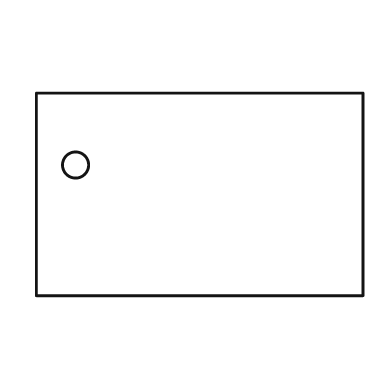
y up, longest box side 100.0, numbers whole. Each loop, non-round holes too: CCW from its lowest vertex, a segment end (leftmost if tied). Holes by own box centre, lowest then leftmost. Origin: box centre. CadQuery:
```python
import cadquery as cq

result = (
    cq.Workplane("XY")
    .moveTo(-50.0, -31.0)
    .lineTo(50.0, -31.0)
    .lineTo(50.0, 31.0)
    .lineTo(-50.0, 31.0)
    .close()
    .moveTo(-38.0, 9.0)
    .circle(4.0)
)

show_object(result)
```